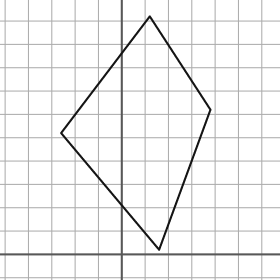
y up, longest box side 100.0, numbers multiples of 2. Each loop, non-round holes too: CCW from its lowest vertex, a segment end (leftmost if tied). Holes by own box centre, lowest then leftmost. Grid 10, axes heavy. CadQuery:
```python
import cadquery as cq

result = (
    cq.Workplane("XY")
    .moveTo(16.0, 2.0)
    .lineTo(38.0, 62.0)
    .lineTo(12.0, 102.0)
    .lineTo(-26.0, 52.0)
    .close()
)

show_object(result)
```